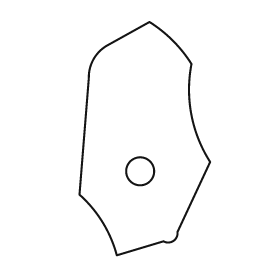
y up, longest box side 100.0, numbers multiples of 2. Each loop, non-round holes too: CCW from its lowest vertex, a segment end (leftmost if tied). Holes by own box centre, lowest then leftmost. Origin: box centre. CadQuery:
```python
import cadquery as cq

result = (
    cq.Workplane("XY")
    .moveTo(-12.0, -50.0)
    .lineTo(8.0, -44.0)
    .threePointArc((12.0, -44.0), (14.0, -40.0))
    .lineTo(28.0, -10.0)
    .threePointArc((20.0, 10.0), (20.0, 32.0))
    .threePointArc((12.0, 42.0), (2.0, 50.0))
    .lineTo(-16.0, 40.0)
    .threePointArc((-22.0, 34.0), (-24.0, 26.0))
    .lineTo(-28.0, -24.0)
    .threePointArc((-18.0, -36.0), (-12.0, -50.0))
    .close()
    .moveTo(-2.0, -14.0)
    .circle(6.0)
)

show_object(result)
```